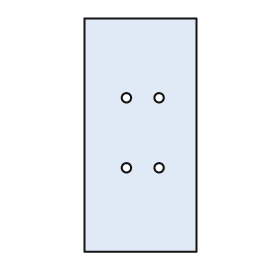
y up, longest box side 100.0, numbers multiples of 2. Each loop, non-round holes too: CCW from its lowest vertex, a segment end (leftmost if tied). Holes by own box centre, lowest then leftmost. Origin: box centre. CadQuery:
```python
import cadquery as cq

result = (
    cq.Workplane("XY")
    .moveTo(-24.0, -50.0)
    .lineTo(24.0, -50.0)
    .lineTo(24.0, 50.0)
    .lineTo(-24.0, 50.0)
    .close()
    .moveTo(-6.0, -14.0)
    .circle(2.0)
    .moveTo(8.0, -14.0)
    .circle(2.0)
    .moveTo(-6.0, 16.0)
    .circle(2.0)
    .moveTo(8.0, 16.0)
    .circle(2.0)
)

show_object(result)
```